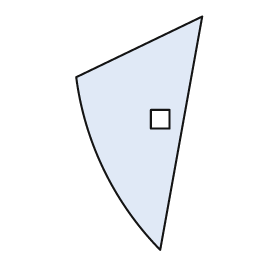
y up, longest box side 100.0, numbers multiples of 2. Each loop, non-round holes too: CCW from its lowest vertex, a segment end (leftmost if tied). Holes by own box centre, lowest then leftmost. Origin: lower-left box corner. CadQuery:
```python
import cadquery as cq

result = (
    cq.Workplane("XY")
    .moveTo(36.0, 0.0)
    .lineTo(54.0, 100.0)
    .lineTo(0.0, 74.0)
    .threePointArc((12.0, 34.0), (36.0, 0.0))
    .close()
    .moveTo(32.0, 52.0)
    .lineTo(40.0, 52.0)
    .lineTo(40.0, 60.0)
    .lineTo(32.0, 60.0)
    .close()
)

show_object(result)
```